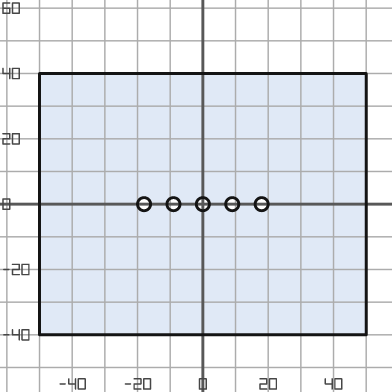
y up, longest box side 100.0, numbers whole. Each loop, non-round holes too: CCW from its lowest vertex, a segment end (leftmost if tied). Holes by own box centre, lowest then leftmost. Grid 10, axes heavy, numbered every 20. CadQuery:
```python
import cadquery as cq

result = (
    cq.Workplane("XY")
    .moveTo(-50.0, -40.0)
    .lineTo(50.0, -40.0)
    .lineTo(50.0, 40.0)
    .lineTo(-50.0, 40.0)
    .close()
    .moveTo(-18.0, 0.0)
    .circle(2.0)
    .moveTo(-9.0, 0.0)
    .circle(2.0)
    .moveTo(0.0, 0.0)
    .circle(2.0)
    .moveTo(9.0, 0.0)
    .circle(2.0)
    .moveTo(18.0, 0.0)
    .circle(2.0)
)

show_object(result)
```